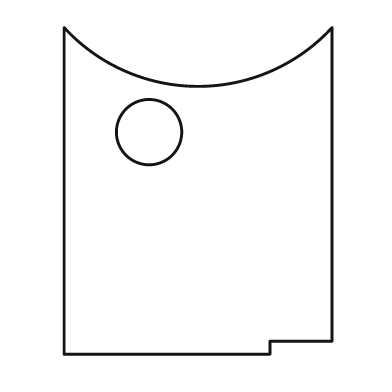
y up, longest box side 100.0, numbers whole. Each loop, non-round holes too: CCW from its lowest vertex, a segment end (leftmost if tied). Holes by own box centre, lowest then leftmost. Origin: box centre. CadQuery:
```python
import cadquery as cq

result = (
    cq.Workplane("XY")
    .moveTo(-41.0, -50.0)
    .lineTo(22.0, -50.0)
    .lineTo(22.0, -46.0)
    .lineTo(41.0, -46.0)
    .lineTo(41.0, 50.0)
    .threePointArc((0.0, 32.0), (-41.0, 50.0))
    .close()
    .moveTo(-15.0, 18.0)
    .circle(10.0)
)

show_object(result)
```